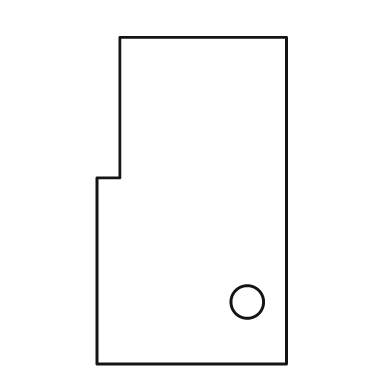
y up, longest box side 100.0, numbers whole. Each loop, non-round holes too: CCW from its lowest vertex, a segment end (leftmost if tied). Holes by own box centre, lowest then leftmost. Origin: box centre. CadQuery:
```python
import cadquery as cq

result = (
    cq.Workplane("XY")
    .moveTo(-29.0, -50.0)
    .lineTo(29.0, -50.0)
    .lineTo(29.0, 50.0)
    .lineTo(-22.0, 50.0)
    .lineTo(-22.0, 7.0)
    .lineTo(-29.0, 7.0)
    .close()
    .moveTo(17.0, -31.0)
    .circle(5.0)
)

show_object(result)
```